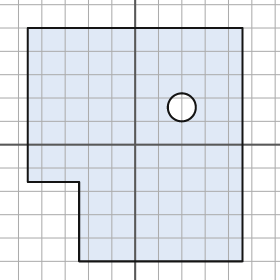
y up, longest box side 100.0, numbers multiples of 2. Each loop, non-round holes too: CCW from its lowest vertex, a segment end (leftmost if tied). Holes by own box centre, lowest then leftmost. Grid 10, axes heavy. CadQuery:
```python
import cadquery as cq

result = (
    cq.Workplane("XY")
    .moveTo(-24.0, -50.0)
    .lineTo(46.0, -50.0)
    .lineTo(46.0, 50.0)
    .lineTo(-46.0, 50.0)
    .lineTo(-46.0, -16.0)
    .lineTo(-24.0, -16.0)
    .close()
    .moveTo(20.0, 16.0)
    .circle(6.0)
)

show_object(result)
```